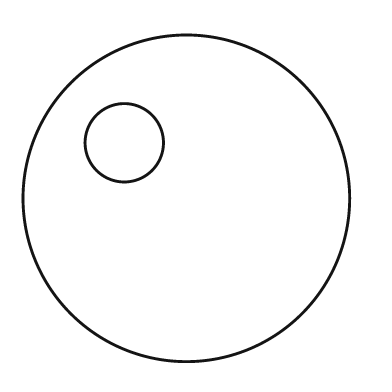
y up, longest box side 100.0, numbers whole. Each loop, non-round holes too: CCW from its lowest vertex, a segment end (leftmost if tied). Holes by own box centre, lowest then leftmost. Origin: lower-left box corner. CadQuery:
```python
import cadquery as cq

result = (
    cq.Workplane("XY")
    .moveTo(50.0, 50.0)
    .circle(50.0)
    .moveTo(31.0, 67.0)
    .circle(12.0)
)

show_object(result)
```